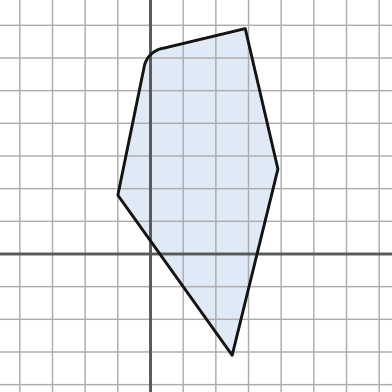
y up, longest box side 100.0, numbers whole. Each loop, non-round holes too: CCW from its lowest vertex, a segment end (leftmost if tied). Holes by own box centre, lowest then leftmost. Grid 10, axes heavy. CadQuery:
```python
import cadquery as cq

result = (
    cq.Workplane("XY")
    .moveTo(25.0, -31.0)
    .lineTo(39.0, 26.0)
    .lineTo(29.0, 69.0)
    .lineTo(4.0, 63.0)
    .threePointArc((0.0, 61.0), (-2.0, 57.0))
    .lineTo(-10.0, 18.0)
    .close()
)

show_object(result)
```